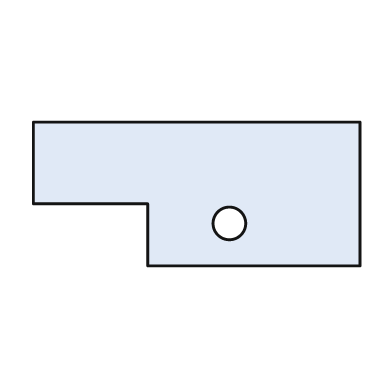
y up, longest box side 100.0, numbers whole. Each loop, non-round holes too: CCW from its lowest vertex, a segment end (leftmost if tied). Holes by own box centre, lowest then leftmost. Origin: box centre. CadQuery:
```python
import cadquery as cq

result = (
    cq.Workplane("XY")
    .moveTo(-15.0, -22.0)
    .lineTo(50.0, -22.0)
    .lineTo(50.0, 22.0)
    .lineTo(-50.0, 22.0)
    .lineTo(-50.0, -3.0)
    .lineTo(-15.0, -3.0)
    .close()
    .moveTo(10.0, -9.0)
    .circle(5.0)
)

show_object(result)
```